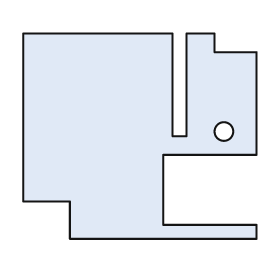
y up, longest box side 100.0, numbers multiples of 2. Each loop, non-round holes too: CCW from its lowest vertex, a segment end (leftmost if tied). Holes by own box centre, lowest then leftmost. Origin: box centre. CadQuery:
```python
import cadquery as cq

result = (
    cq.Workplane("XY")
    .moveTo(-30.0, -44.0)
    .lineTo(50.0, -44.0)
    .lineTo(50.0, -38.0)
    .lineTo(10.0, -38.0)
    .lineTo(10.0, -8.0)
    .lineTo(50.0, -8.0)
    .lineTo(50.0, 36.0)
    .lineTo(32.0, 36.0)
    .lineTo(32.0, 44.0)
    .lineTo(20.0, 44.0)
    .lineTo(20.0, 0.0)
    .lineTo(14.0, 0.0)
    .lineTo(14.0, 44.0)
    .lineTo(-50.0, 44.0)
    .lineTo(-50.0, -28.0)
    .lineTo(-30.0, -28.0)
    .close()
    .moveTo(36.0, 2.0)
    .circle(4.0)
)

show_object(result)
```